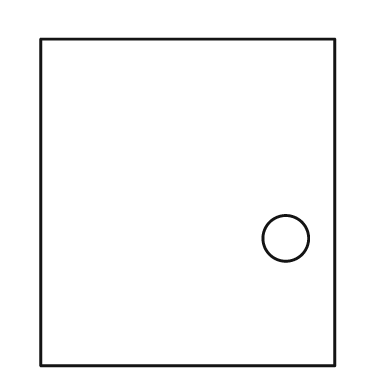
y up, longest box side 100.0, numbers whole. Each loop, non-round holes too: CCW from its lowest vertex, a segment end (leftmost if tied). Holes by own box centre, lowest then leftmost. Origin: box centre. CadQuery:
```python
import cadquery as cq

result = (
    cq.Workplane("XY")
    .moveTo(-45.0, -50.0)
    .lineTo(45.0, -50.0)
    .lineTo(45.0, 50.0)
    .lineTo(-45.0, 50.0)
    .close()
    .moveTo(30.0, -11.0)
    .circle(7.0)
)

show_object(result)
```